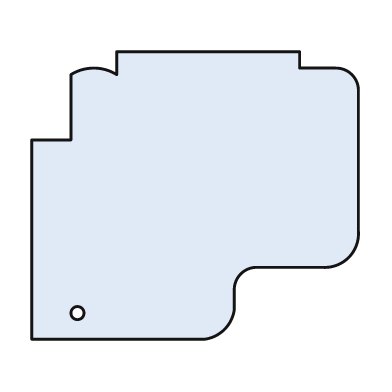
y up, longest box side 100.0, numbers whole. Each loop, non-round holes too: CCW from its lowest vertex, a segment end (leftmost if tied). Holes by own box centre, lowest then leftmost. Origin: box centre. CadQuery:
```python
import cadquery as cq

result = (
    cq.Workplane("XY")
    .moveTo(-50.0, -44.0)
    .lineTo(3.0, -44.0)
    .threePointArc((9.0, -41.0), (12.0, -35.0))
    .lineTo(12.0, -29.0)
    .threePointArc((14.0, -24.0), (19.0, -22.0))
    .lineTo(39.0, -22.0)
    .threePointArc((47.0, -19.0), (50.0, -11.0))
    .lineTo(50.0, 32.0)
    .threePointArc((48.0, 37.0), (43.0, 39.0))
    .lineTo(32.0, 39.0)
    .lineTo(32.0, 44.0)
    .lineTo(-24.0, 44.0)
    .lineTo(-24.0, 37.0)
    .threePointArc((-31.0, 39.0), (-38.0, 37.0))
    .lineTo(-38.0, 17.0)
    .lineTo(-50.0, 17.0)
    .close()
    .moveTo(-36.0, -36.0)
    .circle(2.0)
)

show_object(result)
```